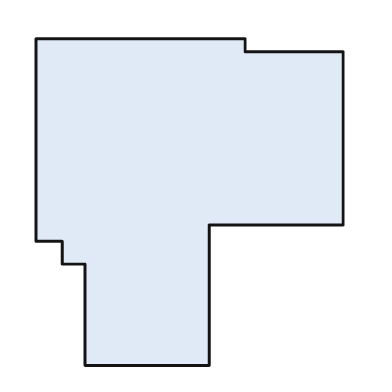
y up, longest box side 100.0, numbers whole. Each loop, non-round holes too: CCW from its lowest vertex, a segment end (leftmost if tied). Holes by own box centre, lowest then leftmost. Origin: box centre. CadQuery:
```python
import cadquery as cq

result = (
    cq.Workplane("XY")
    .moveTo(-32.0, -50.0)
    .lineTo(6.0, -50.0)
    .lineTo(6.0, -7.0)
    .lineTo(47.0, -7.0)
    .lineTo(47.0, 46.0)
    .lineTo(17.0, 46.0)
    .lineTo(17.0, 50.0)
    .lineTo(-47.0, 50.0)
    .lineTo(-47.0, -12.0)
    .lineTo(-39.0, -12.0)
    .lineTo(-39.0, -19.0)
    .lineTo(-32.0, -19.0)
    .close()
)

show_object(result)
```